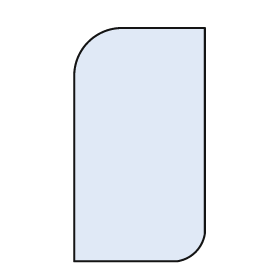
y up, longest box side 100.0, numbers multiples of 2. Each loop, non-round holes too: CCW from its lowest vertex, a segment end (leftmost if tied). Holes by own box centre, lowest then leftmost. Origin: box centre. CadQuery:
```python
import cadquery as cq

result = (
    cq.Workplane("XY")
    .moveTo(-28.0, -50.0)
    .lineTo(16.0, -50.0)
    .threePointArc((24.0, -46.0), (28.0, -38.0))
    .lineTo(28.0, 50.0)
    .lineTo(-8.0, 50.0)
    .threePointArc((-22.0, 44.0), (-28.0, 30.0))
    .close()
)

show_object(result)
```